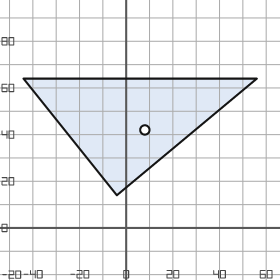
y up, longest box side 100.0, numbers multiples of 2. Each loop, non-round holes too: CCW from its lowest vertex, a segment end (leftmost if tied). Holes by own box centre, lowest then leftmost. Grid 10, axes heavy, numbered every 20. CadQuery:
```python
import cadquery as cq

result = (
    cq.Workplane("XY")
    .moveTo(-4.0, 14.0)
    .lineTo(56.0, 64.0)
    .lineTo(-44.0, 64.0)
    .close()
    .moveTo(8.0, 42.0)
    .circle(2.0)
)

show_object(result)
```